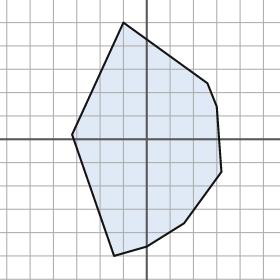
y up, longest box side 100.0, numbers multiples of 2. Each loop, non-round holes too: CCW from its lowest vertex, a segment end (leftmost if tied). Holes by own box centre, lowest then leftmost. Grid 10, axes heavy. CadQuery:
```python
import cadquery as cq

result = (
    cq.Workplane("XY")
    .moveTo(-14.0, -50.0)
    .lineTo(0.0, -46.0)
    .lineTo(16.0, -36.0)
    .lineTo(32.0, -14.0)
    .lineTo(30.0, 14.0)
    .lineTo(26.0, 24.0)
    .lineTo(-10.0, 50.0)
    .lineTo(-32.0, 2.0)
    .close()
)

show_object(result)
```